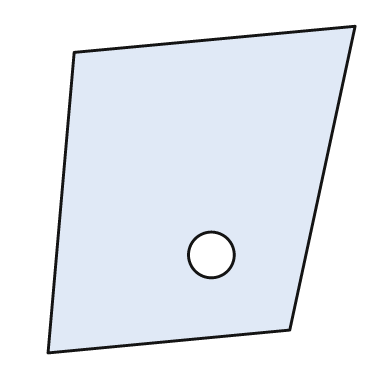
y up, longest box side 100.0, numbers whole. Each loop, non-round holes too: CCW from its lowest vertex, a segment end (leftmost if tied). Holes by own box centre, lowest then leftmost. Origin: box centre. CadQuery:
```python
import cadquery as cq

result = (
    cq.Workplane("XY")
    .moveTo(-47.0, -50.0)
    .lineTo(27.0, -43.0)
    .lineTo(47.0, 50.0)
    .lineTo(-39.0, 42.0)
    .close()
    .moveTo(3.0, -20.0)
    .circle(7.0)
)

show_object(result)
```